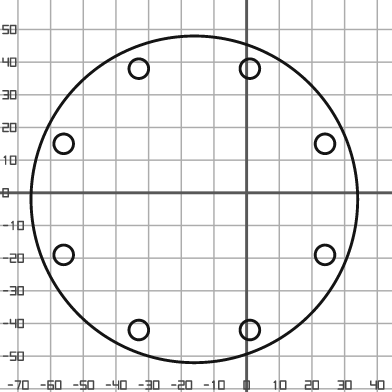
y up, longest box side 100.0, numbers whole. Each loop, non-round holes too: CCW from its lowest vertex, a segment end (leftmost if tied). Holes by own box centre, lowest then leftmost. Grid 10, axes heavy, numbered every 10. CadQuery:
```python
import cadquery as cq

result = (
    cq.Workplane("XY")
    .moveTo(-16.0, -2.0)
    .circle(50.0)
    .moveTo(-33.0, -42.0)
    .circle(3.0)
    .moveTo(1.0, -42.0)
    .circle(3.0)
    .moveTo(-56.0, -19.0)
    .circle(3.0)
    .moveTo(24.0, -19.0)
    .circle(3.0)
    .moveTo(-56.0, 15.0)
    .circle(3.0)
    .moveTo(24.0, 15.0)
    .circle(3.0)
    .moveTo(-33.0, 38.0)
    .circle(3.0)
    .moveTo(1.0, 38.0)
    .circle(3.0)
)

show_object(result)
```